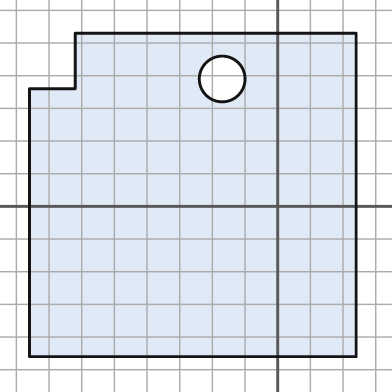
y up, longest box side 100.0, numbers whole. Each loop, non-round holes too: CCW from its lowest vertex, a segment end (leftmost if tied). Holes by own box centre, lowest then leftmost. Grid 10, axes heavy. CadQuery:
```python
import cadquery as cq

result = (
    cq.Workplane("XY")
    .moveTo(-76.0, -46.0)
    .lineTo(24.0, -46.0)
    .lineTo(24.0, 53.0)
    .lineTo(-62.0, 53.0)
    .lineTo(-62.0, 36.0)
    .lineTo(-76.0, 36.0)
    .close()
    .moveTo(-17.0, 39.0)
    .circle(7.0)
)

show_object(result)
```